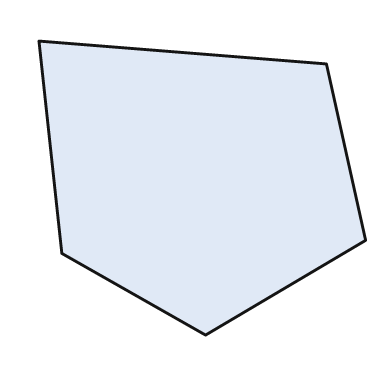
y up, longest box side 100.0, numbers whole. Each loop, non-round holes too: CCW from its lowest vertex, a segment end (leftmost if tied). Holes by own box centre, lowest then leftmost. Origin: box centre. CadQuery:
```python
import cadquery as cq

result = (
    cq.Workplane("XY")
    .moveTo(1.0, -45.0)
    .lineTo(50.0, -16.0)
    .lineTo(38.0, 38.0)
    .lineTo(-50.0, 45.0)
    .lineTo(-43.0, -20.0)
    .close()
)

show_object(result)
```